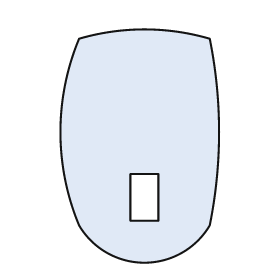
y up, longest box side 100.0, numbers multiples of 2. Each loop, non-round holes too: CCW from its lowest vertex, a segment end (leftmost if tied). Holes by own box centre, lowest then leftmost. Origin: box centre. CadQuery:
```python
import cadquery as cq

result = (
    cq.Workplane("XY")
    .moveTo(-26.0, -34.0)
    .threePointArc((2.0, -50.0), (30.0, -34.0))
    .threePointArc((34.0, 6.0), (30.0, 46.0))
    .threePointArc((2.0, 50.0), (-26.0, 46.0))
    .threePointArc((-34.0, 6.0), (-26.0, -34.0))
    .close()
    .moveTo(-4.0, -32.0)
    .lineTo(8.0, -32.0)
    .lineTo(8.0, -12.0)
    .lineTo(-4.0, -12.0)
    .close()
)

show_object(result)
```